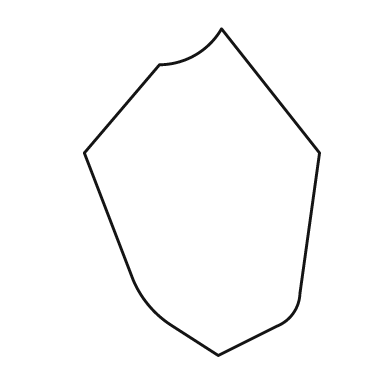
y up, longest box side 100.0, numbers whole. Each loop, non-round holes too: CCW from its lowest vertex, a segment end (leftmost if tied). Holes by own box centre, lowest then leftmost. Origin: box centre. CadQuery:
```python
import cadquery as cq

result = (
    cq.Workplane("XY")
    .moveTo(5.0, -50.0)
    .lineTo(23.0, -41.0)
    .threePointArc((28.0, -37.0), (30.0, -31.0))
    .lineTo(36.0, 12.0)
    .lineTo(6.0, 50.0)
    .threePointArc((-2.0, 42.0), (-13.0, 39.0))
    .lineTo(-36.0, 12.0)
    .lineTo(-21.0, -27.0)
    .threePointArc((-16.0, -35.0), (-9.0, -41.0))
    .close()
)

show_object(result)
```